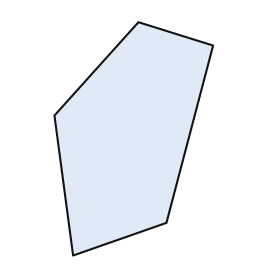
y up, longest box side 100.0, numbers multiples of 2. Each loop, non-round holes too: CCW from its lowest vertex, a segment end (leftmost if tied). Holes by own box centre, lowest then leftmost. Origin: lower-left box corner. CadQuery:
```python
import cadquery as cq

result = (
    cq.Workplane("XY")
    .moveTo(8.0, 0.0)
    .lineTo(48.0, 14.0)
    .lineTo(68.0, 90.0)
    .lineTo(36.0, 100.0)
    .lineTo(0.0, 60.0)
    .close()
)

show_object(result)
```